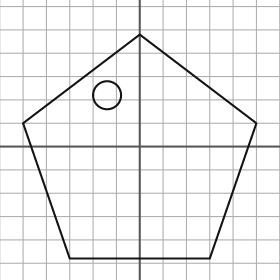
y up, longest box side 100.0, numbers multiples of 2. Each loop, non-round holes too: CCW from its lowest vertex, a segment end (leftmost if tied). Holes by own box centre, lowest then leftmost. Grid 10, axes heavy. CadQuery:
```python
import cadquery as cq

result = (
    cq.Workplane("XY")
    .moveTo(-30.0, -48.0)
    .lineTo(30.0, -48.0)
    .lineTo(50.0, 10.0)
    .lineTo(0.0, 48.0)
    .lineTo(-50.0, 10.0)
    .close()
    .moveTo(-14.0, 22.0)
    .circle(6.0)
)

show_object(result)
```